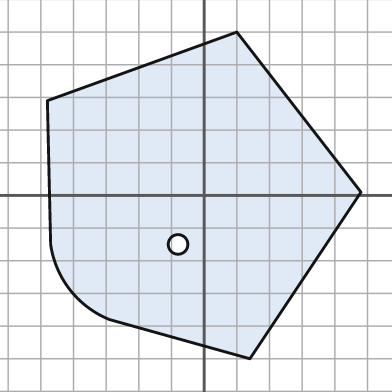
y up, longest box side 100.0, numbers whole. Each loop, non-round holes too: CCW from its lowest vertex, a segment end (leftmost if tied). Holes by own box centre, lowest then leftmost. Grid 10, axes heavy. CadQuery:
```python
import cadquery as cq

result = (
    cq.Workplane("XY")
    .moveTo(14.0, -50.0)
    .lineTo(48.0, 1.0)
    .lineTo(10.0, 50.0)
    .lineTo(-48.0, 29.0)
    .lineTo(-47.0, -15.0)
    .threePointArc((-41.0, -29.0), (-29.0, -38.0))
    .close()
    .moveTo(-8.0, -15.0)
    .circle(3.0)
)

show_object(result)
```